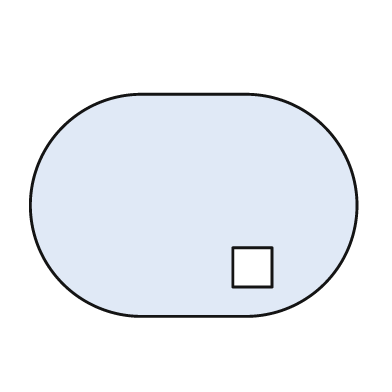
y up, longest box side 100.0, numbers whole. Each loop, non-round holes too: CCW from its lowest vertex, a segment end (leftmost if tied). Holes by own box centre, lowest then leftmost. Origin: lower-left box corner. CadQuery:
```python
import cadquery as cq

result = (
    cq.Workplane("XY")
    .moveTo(34.0, 0.0)
    .lineTo(66.0, 0.0)
    .threePointArc((100.0, 34.0), (66.0, 68.0))
    .lineTo(34.0, 68.0)
    .threePointArc((0.0, 34.0), (34.0, 0.0))
    .close()
    .moveTo(62.0, 9.0)
    .lineTo(74.0, 9.0)
    .lineTo(74.0, 21.0)
    .lineTo(62.0, 21.0)
    .close()
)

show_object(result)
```